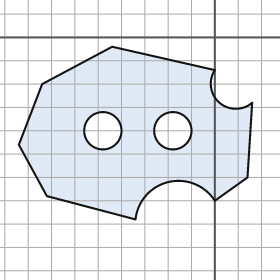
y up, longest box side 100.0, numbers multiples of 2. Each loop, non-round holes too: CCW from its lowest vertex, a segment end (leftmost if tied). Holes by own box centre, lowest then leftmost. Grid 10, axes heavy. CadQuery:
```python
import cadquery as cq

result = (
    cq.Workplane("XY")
    .moveTo(-34.0, -78.0)
    .threePointArc((-20.0, -62.0), (0.0, -70.0))
    .lineTo(14.0, -60.0)
    .lineTo(16.0, -28.0)
    .threePointArc((2.0, -28.0), (0.0, -14.0))
    .lineTo(-44.0, -4.0)
    .lineTo(-74.0, -20.0)
    .lineTo(-84.0, -46.0)
    .lineTo(-72.0, -68.0)
    .close()
    .moveTo(-48.0, -40.0)
    .circle(8.0)
    .moveTo(-18.0, -40.0)
    .circle(8.0)
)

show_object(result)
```